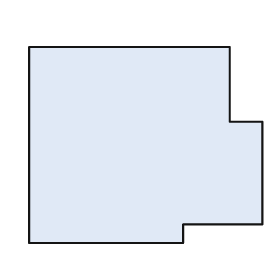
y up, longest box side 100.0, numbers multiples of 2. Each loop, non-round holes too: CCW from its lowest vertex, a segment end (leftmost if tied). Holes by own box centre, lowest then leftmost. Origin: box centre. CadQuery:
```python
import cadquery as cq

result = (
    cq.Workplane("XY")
    .moveTo(-50.0, -42.0)
    .lineTo(16.0, -42.0)
    .lineTo(16.0, -34.0)
    .lineTo(50.0, -34.0)
    .lineTo(50.0, 10.0)
    .lineTo(36.0, 10.0)
    .lineTo(36.0, 42.0)
    .lineTo(-50.0, 42.0)
    .close()
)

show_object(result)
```